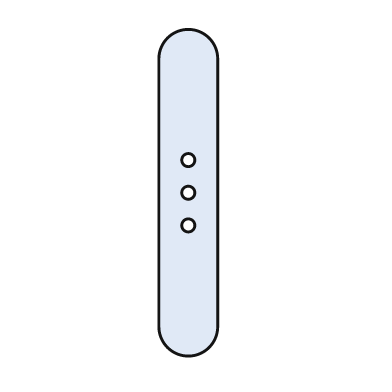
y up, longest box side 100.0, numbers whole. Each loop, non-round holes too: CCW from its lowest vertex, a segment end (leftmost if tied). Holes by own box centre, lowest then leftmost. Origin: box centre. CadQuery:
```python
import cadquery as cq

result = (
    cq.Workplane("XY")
    .moveTo(-9.0, -41.0)
    .threePointArc((0.0, -50.0), (9.0, -41.0))
    .lineTo(9.0, 41.0)
    .threePointArc((0.0, 50.0), (-9.0, 41.0))
    .close()
    .moveTo(0.0, -10.0)
    .circle(2.0)
    .moveTo(0.0, 0.0)
    .circle(2.0)
    .moveTo(0.0, 10.0)
    .circle(2.0)
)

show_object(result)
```